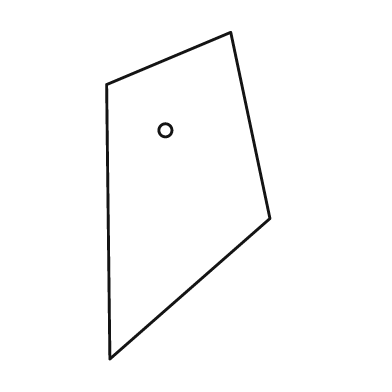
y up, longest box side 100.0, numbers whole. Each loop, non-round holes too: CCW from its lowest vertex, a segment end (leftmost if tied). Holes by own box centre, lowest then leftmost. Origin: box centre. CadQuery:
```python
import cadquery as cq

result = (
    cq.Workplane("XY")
    .moveTo(-24.0, -50.0)
    .lineTo(25.0, -7.0)
    .lineTo(13.0, 50.0)
    .lineTo(-25.0, 34.0)
    .close()
    .moveTo(-7.0, 20.0)
    .circle(2.0)
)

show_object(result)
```